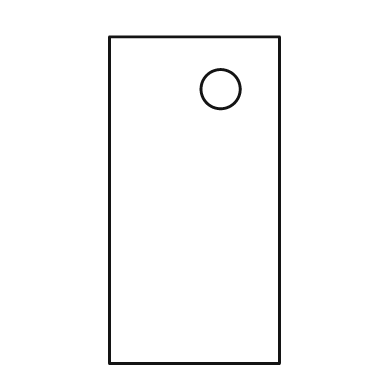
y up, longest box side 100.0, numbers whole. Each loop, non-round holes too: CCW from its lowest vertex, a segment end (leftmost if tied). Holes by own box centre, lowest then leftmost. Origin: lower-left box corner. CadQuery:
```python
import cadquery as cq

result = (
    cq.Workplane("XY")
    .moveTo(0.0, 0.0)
    .lineTo(52.0, 0.0)
    .lineTo(52.0, 100.0)
    .lineTo(0.0, 100.0)
    .close()
    .moveTo(34.0, 84.0)
    .circle(6.0)
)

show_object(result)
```